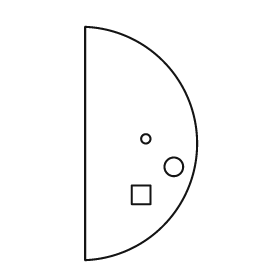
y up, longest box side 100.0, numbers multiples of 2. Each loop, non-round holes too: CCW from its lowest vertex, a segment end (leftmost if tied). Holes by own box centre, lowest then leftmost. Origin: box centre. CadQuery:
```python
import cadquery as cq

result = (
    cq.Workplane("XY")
    .moveTo(-24.0, -50.0)
    .threePointArc((24.0, 0.0), (-24.0, 50.0))
    .close()
    .moveTo(-4.0, -26.0)
    .lineTo(4.0, -26.0)
    .lineTo(4.0, -18.0)
    .lineTo(-4.0, -18.0)
    .close()
    .moveTo(14.0, -10.0)
    .circle(4.0)
    .moveTo(2.0, 2.0)
    .circle(2.0)
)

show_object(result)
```